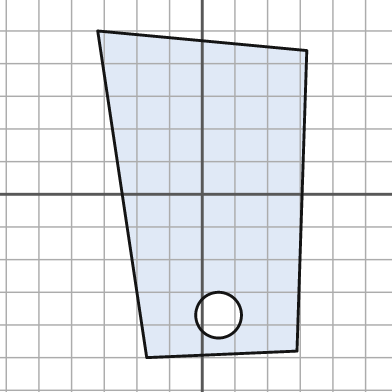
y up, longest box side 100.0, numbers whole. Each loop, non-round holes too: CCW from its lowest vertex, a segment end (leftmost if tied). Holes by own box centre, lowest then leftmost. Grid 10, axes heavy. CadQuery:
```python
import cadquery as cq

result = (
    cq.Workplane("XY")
    .moveTo(-17.0, -50.0)
    .lineTo(29.0, -48.0)
    .lineTo(32.0, 44.0)
    .lineTo(-32.0, 50.0)
    .close()
    .moveTo(5.0, -37.0)
    .circle(7.0)
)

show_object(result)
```